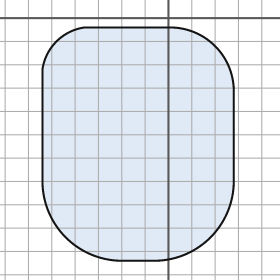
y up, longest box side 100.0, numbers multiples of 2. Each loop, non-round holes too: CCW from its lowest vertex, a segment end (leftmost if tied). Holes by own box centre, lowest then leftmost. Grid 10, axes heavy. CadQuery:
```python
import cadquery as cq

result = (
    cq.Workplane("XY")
    .moveTo(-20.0, -104.0)
    .lineTo(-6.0, -104.0)
    .threePointArc((18.0, -94.0), (28.0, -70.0))
    .lineTo(28.0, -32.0)
    .threePointArc((20.0, -12.0), (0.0, -4.0))
    .lineTo(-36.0, -4.0)
    .threePointArc((-48.0, -10.0), (-54.0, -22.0))
    .lineTo(-54.0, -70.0)
    .threePointArc((-44.0, -94.0), (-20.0, -104.0))
    .close()
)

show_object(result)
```